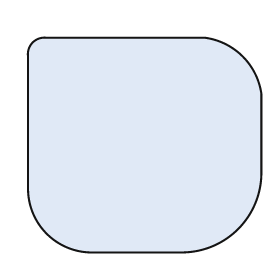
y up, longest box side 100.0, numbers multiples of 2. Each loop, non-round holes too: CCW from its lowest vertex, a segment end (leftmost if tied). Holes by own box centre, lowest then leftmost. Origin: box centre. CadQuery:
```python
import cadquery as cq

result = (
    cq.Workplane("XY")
    .moveTo(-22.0, -46.0)
    .lineTo(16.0, -46.0)
    .threePointArc((40.0, -36.0), (50.0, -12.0))
    .lineTo(50.0, 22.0)
    .threePointArc((42.0, 38.0), (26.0, 46.0))
    .lineTo(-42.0, 46.0)
    .threePointArc((-48.0, 44.0), (-50.0, 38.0))
    .lineTo(-50.0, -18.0)
    .threePointArc((-42.0, -38.0), (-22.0, -46.0))
    .close()
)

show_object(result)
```